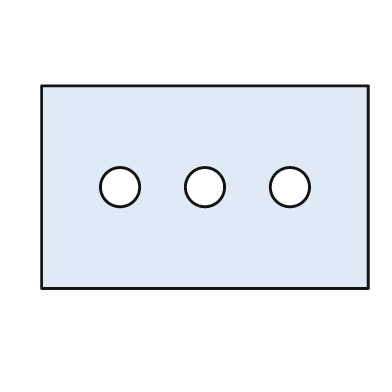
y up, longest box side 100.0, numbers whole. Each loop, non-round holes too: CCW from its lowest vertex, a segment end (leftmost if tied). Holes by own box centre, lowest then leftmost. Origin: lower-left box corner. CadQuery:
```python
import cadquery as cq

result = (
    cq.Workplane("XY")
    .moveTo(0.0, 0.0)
    .lineTo(100.0, 0.0)
    .lineTo(100.0, 62.0)
    .lineTo(0.0, 62.0)
    .close()
    .moveTo(24.0, 31.0)
    .circle(6.0)
    .moveTo(50.0, 31.0)
    .circle(6.0)
    .moveTo(76.0, 31.0)
    .circle(6.0)
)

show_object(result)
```